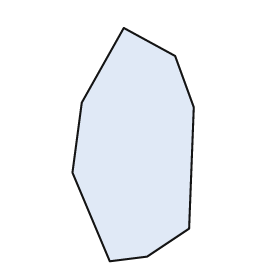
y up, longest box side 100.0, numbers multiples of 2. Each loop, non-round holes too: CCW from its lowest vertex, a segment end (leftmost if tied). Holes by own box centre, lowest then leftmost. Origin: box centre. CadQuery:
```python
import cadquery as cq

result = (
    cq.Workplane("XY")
    .moveTo(-10.0, -50.0)
    .lineTo(6.0, -48.0)
    .lineTo(24.0, -36.0)
    .lineTo(26.0, 16.0)
    .lineTo(18.0, 38.0)
    .lineTo(-4.0, 50.0)
    .lineTo(-22.0, 18.0)
    .lineTo(-26.0, -12.0)
    .close()
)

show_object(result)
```